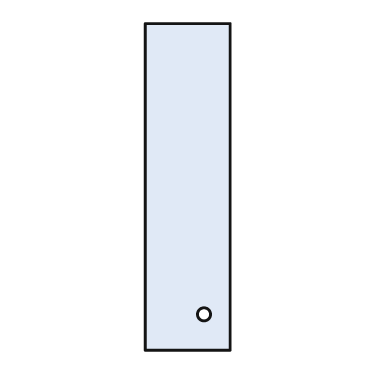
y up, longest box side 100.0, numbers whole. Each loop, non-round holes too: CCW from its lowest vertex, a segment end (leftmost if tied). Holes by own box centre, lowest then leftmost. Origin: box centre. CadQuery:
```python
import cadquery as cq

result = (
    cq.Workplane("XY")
    .moveTo(-13.0, -50.0)
    .lineTo(13.0, -50.0)
    .lineTo(13.0, 50.0)
    .lineTo(-13.0, 50.0)
    .close()
    .moveTo(5.0, -39.0)
    .circle(2.0)
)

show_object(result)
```